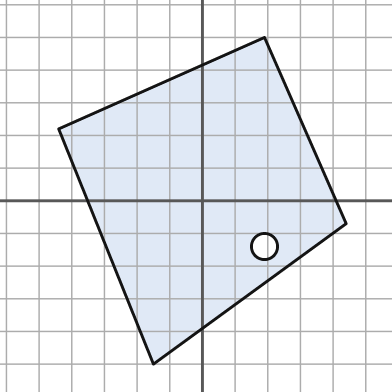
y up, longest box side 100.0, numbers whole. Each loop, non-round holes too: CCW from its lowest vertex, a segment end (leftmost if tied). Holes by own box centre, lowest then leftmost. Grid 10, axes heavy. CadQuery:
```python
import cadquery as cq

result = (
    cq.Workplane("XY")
    .moveTo(-15.0, -50.0)
    .lineTo(44.0, -7.0)
    .lineTo(19.0, 50.0)
    .lineTo(-44.0, 22.0)
    .close()
    .moveTo(19.0, -14.0)
    .circle(4.0)
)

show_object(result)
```